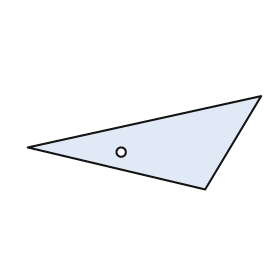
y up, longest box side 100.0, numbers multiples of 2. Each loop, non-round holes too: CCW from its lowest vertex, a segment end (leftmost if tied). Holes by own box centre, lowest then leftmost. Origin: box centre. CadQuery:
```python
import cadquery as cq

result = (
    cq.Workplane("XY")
    .moveTo(26.0, -20.0)
    .lineTo(50.0, 20.0)
    .lineTo(-50.0, -2.0)
    .close()
    .moveTo(-10.0, -4.0)
    .circle(2.0)
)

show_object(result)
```